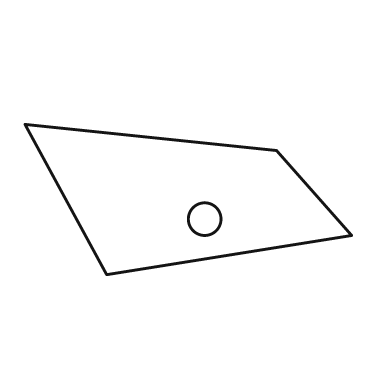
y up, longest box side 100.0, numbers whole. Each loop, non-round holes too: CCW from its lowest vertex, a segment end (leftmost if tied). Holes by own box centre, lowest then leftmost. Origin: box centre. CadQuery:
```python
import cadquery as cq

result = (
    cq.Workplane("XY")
    .moveTo(-25.0, -23.0)
    .lineTo(50.0, -11.0)
    .lineTo(27.0, 15.0)
    .lineTo(-50.0, 23.0)
    .close()
    .moveTo(5.0, -6.0)
    .circle(5.0)
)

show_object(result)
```